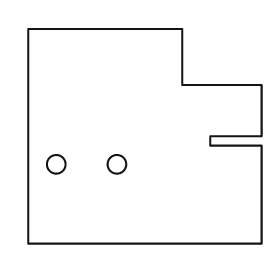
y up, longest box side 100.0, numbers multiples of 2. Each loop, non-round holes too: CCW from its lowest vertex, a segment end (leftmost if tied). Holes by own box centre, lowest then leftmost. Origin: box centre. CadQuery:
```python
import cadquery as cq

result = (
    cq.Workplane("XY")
    .moveTo(-50.0, -46.0)
    .lineTo(50.0, -46.0)
    .lineTo(50.0, -4.0)
    .lineTo(28.0, -4.0)
    .lineTo(28.0, 0.0)
    .lineTo(50.0, 0.0)
    .lineTo(50.0, 22.0)
    .lineTo(16.0, 22.0)
    .lineTo(16.0, 46.0)
    .lineTo(-50.0, 46.0)
    .close()
    .moveTo(-38.0, -12.0)
    .circle(4.0)
    .moveTo(-12.0, -12.0)
    .circle(4.0)
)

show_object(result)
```